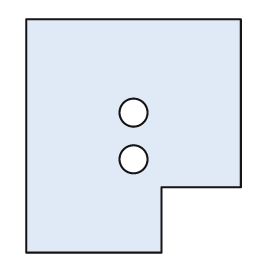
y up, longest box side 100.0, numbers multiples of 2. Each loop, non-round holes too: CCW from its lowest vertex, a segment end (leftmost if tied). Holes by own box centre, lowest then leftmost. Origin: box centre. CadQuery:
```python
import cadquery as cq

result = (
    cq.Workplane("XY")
    .moveTo(-46.0, -50.0)
    .lineTo(12.0, -50.0)
    .lineTo(12.0, -22.0)
    .lineTo(46.0, -22.0)
    .lineTo(46.0, 50.0)
    .lineTo(-46.0, 50.0)
    .close()
    .moveTo(0.0, -10.0)
    .circle(6.0)
    .moveTo(0.0, 10.0)
    .circle(6.0)
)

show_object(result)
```